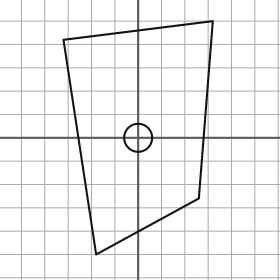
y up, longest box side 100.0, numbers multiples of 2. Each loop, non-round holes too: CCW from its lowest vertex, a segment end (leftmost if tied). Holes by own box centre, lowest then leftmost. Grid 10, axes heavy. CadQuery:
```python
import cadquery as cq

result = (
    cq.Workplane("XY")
    .moveTo(-18.0, -50.0)
    .lineTo(26.0, -26.0)
    .lineTo(32.0, 50.0)
    .lineTo(-32.0, 42.0)
    .close()
    .moveTo(0.0, 0.0)
    .circle(6.0)
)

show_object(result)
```